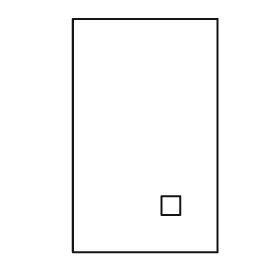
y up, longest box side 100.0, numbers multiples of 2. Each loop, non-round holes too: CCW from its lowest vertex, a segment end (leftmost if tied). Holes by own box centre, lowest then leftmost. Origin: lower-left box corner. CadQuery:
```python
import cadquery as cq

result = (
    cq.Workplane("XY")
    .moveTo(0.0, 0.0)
    .lineTo(62.0, 0.0)
    .lineTo(62.0, 100.0)
    .lineTo(0.0, 100.0)
    .close()
    .moveTo(38.0, 16.0)
    .lineTo(46.0, 16.0)
    .lineTo(46.0, 24.0)
    .lineTo(38.0, 24.0)
    .close()
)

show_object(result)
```